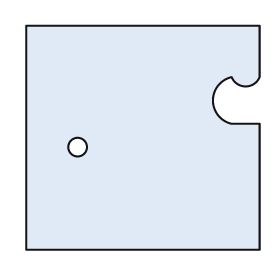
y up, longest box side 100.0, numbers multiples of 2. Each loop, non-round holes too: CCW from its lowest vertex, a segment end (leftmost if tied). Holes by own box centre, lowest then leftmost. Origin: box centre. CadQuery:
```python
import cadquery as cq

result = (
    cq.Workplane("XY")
    .moveTo(-50.0, -48.0)
    .lineTo(50.0, -48.0)
    .lineTo(50.0, 6.0)
    .lineTo(38.0, 6.0)
    .threePointArc((30.0, 16.0), (38.0, 26.0))
    .threePointArc((44.0, 22.0), (50.0, 26.0))
    .lineTo(50.0, 48.0)
    .lineTo(-50.0, 48.0)
    .close()
    .moveTo(-28.0, -4.0)
    .circle(4.0)
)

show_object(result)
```